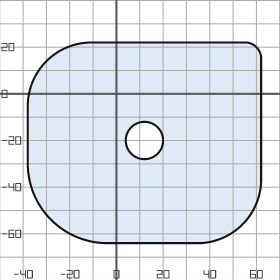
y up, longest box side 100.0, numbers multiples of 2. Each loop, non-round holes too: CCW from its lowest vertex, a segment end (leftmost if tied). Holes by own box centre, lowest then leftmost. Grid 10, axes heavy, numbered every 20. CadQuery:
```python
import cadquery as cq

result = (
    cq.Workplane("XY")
    .moveTo(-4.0, -64.0)
    .lineTo(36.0, -64.0)
    .threePointArc((54.0, -56.0), (62.0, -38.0))
    .lineTo(62.0, 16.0)
    .threePointArc((60.0, 20.0), (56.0, 22.0))
    .lineTo(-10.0, 22.0)
    .threePointArc((-30.0, 14.0), (-38.0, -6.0))
    .lineTo(-38.0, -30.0)
    .threePointArc((-28.0, -54.0), (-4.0, -64.0))
    .close()
    .moveTo(12.0, -20.0)
    .circle(8.0)
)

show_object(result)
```